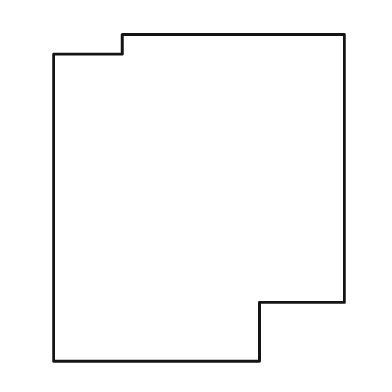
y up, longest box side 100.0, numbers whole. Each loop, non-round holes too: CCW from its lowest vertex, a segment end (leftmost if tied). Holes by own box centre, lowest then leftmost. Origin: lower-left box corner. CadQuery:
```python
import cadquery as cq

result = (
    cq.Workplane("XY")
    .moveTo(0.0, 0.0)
    .lineTo(63.0, 0.0)
    .lineTo(63.0, 18.0)
    .lineTo(89.0, 18.0)
    .lineTo(89.0, 100.0)
    .lineTo(21.0, 100.0)
    .lineTo(21.0, 94.0)
    .lineTo(0.0, 94.0)
    .close()
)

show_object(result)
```